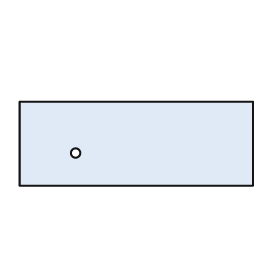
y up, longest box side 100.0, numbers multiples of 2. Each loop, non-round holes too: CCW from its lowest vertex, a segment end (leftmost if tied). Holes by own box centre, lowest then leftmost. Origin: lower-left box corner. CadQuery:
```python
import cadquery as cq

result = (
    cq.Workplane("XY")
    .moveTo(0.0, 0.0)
    .lineTo(100.0, 0.0)
    .lineTo(100.0, 36.0)
    .lineTo(0.0, 36.0)
    .close()
    .moveTo(24.0, 14.0)
    .circle(2.0)
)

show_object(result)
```